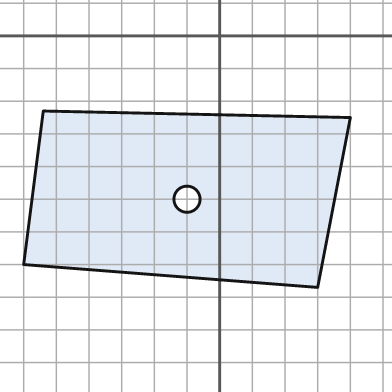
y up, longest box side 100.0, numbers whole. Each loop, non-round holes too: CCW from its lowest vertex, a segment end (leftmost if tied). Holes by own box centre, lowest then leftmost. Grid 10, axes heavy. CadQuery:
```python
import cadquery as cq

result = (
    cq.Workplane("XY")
    .moveTo(30.0, -77.0)
    .lineTo(40.0, -25.0)
    .lineTo(-54.0, -23.0)
    .lineTo(-60.0, -70.0)
    .close()
    .moveTo(-10.0, -50.0)
    .circle(4.0)
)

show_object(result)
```